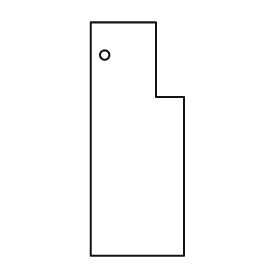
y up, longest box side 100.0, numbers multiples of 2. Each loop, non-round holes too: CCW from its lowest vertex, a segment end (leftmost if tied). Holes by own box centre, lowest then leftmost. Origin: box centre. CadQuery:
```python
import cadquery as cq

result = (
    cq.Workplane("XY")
    .moveTo(-20.0, -50.0)
    .lineTo(20.0, -50.0)
    .lineTo(20.0, 18.0)
    .lineTo(8.0, 18.0)
    .lineTo(8.0, 50.0)
    .lineTo(-20.0, 50.0)
    .close()
    .moveTo(-14.0, 36.0)
    .circle(2.0)
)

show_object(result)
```